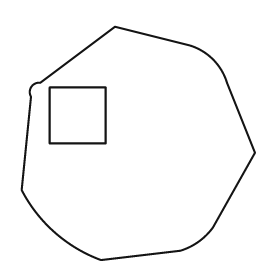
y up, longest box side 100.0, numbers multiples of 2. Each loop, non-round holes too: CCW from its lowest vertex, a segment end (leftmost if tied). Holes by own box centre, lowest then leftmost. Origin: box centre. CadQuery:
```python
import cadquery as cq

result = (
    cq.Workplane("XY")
    .moveTo(-16.0, -50.0)
    .lineTo(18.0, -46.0)
    .threePointArc((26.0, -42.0), (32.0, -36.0))
    .lineTo(50.0, -4.0)
    .lineTo(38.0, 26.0)
    .threePointArc((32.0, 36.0), (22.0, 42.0))
    .lineTo(-10.0, 50.0)
    .lineTo(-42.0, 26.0)
    .threePointArc((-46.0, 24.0), (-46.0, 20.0))
    .lineTo(-50.0, -20.0)
    .threePointArc((-36.0, -38.0), (-16.0, -50.0))
    .close()
    .moveTo(-38.0, 0.0)
    .lineTo(-14.0, 0.0)
    .lineTo(-14.0, 24.0)
    .lineTo(-38.0, 24.0)
    .close()
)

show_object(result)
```